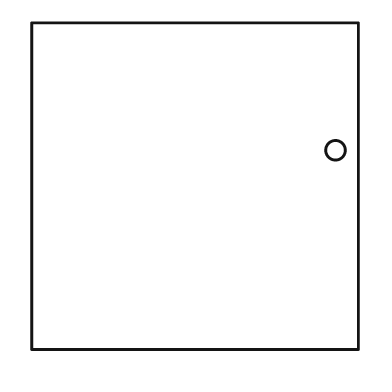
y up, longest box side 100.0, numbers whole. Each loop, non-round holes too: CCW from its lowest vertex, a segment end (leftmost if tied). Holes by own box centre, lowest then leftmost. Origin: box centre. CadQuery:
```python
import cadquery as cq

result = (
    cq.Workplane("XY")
    .moveTo(-50.0, -50.0)
    .lineTo(50.0, -50.0)
    .lineTo(50.0, 50.0)
    .lineTo(-50.0, 50.0)
    .close()
    .moveTo(43.0, 11.0)
    .circle(3.0)
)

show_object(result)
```